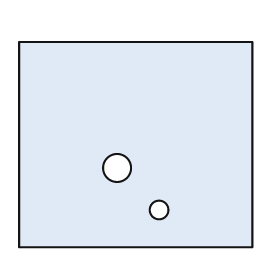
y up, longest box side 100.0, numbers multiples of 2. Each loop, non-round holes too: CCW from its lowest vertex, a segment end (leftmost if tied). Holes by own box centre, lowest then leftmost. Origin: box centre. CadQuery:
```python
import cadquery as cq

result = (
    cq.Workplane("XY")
    .moveTo(-50.0, -44.0)
    .lineTo(50.0, -44.0)
    .lineTo(50.0, 44.0)
    .lineTo(-50.0, 44.0)
    .close()
    .moveTo(10.0, -28.0)
    .circle(4.0)
    .moveTo(-8.0, -10.0)
    .circle(6.0)
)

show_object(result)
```